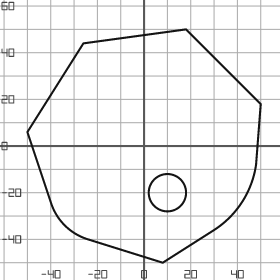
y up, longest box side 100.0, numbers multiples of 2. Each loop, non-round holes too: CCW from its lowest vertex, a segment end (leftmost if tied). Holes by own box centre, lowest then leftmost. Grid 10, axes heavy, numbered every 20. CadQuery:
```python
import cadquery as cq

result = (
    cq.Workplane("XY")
    .moveTo(8.0, -50.0)
    .lineTo(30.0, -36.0)
    .threePointArc((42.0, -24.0), (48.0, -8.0))
    .lineTo(50.0, 18.0)
    .lineTo(18.0, 50.0)
    .lineTo(-26.0, 44.0)
    .lineTo(-50.0, 6.0)
    .lineTo(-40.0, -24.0)
    .threePointArc((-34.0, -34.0), (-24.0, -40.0))
    .close()
    .moveTo(10.0, -20.0)
    .circle(8.0)
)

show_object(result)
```